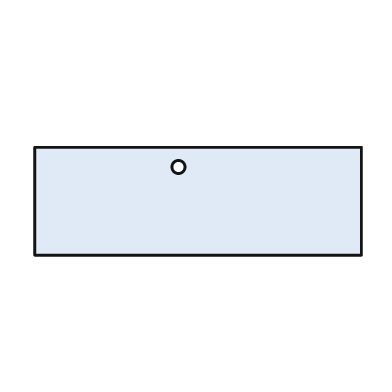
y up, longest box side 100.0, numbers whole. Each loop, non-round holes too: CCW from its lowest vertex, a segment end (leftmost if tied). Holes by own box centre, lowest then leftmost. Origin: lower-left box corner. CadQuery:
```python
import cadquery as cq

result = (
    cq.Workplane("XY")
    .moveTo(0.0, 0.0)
    .lineTo(100.0, 0.0)
    .lineTo(100.0, 33.0)
    .lineTo(0.0, 33.0)
    .close()
    .moveTo(44.0, 27.0)
    .circle(2.0)
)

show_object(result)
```